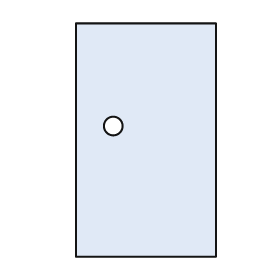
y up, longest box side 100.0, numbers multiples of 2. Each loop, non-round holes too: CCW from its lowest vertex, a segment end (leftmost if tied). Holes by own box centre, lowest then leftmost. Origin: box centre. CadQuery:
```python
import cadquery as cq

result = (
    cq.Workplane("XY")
    .moveTo(-30.0, -50.0)
    .lineTo(30.0, -50.0)
    .lineTo(30.0, 50.0)
    .lineTo(-30.0, 50.0)
    .close()
    .moveTo(-14.0, 6.0)
    .circle(4.0)
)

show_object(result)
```